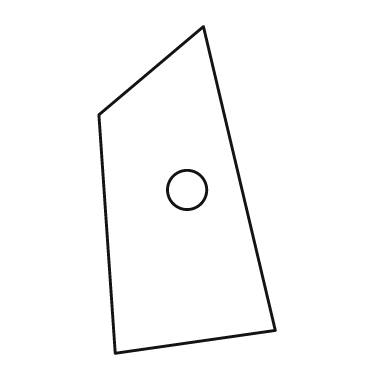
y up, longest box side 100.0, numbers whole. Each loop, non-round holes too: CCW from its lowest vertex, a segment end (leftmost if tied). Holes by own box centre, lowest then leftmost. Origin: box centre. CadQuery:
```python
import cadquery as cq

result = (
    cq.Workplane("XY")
    .moveTo(-22.0, -50.0)
    .lineTo(27.0, -43.0)
    .lineTo(5.0, 50.0)
    .lineTo(-27.0, 23.0)
    .close()
    .moveTo(0.0, 0.0)
    .circle(6.0)
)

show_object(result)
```